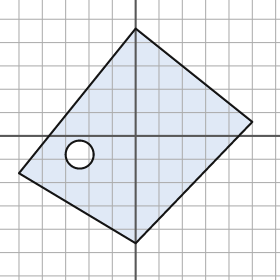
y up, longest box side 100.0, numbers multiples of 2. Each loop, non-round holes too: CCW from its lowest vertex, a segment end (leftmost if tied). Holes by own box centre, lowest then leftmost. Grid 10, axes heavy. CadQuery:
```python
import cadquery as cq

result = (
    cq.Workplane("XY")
    .moveTo(0.0, -46.0)
    .lineTo(50.0, 6.0)
    .lineTo(0.0, 46.0)
    .lineTo(-50.0, -16.0)
    .close()
    .moveTo(-24.0, -8.0)
    .circle(6.0)
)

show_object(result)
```